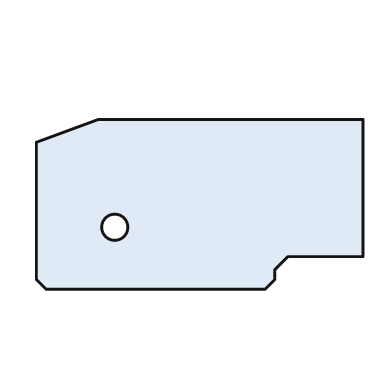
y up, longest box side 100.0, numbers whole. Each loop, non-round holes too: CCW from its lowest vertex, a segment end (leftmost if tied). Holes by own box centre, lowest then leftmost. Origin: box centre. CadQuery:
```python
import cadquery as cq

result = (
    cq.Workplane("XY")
    .moveTo(-47.0, -26.0)
    .lineTo(20.0, -26.0)
    .lineTo(23.0, -23.0)
    .lineTo(23.0, -20.0)
    .lineTo(27.0, -16.0)
    .lineTo(50.0, -16.0)
    .lineTo(50.0, 26.0)
    .lineTo(-31.0, 26.0)
    .lineTo(-50.0, 19.0)
    .lineTo(-50.0, -23.0)
    .close()
    .moveTo(-26.0, -7.0)
    .circle(4.0)
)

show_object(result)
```